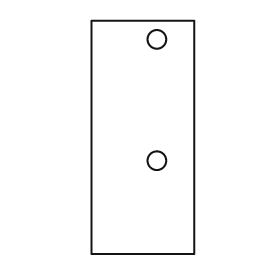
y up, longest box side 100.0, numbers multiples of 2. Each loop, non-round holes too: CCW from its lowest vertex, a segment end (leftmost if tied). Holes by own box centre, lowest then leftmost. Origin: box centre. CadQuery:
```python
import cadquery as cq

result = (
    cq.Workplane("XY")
    .moveTo(-22.0, -50.0)
    .lineTo(22.0, -50.0)
    .lineTo(22.0, 50.0)
    .lineTo(-22.0, 50.0)
    .close()
    .moveTo(6.0, -10.0)
    .circle(4.0)
    .moveTo(6.0, 42.0)
    .circle(4.0)
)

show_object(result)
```